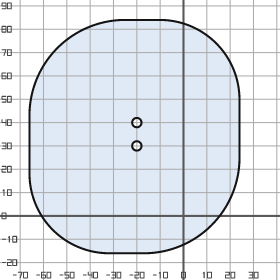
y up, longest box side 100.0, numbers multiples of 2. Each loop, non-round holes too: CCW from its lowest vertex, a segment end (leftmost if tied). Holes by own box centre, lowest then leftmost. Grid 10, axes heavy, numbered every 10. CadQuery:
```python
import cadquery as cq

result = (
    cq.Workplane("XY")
    .moveTo(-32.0, -16.0)
    .lineTo(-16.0, -16.0)
    .threePointArc((12.0, -4.0), (24.0, 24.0))
    .lineTo(24.0, 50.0)
    .threePointArc((14.0, 74.0), (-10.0, 84.0))
    .lineTo(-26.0, 84.0)
    .threePointArc((-54.0, 72.0), (-66.0, 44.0))
    .lineTo(-66.0, 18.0)
    .threePointArc((-56.0, -6.0), (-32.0, -16.0))
    .close()
    .moveTo(-20.0, 30.0)
    .circle(2.0)
    .moveTo(-20.0, 40.0)
    .circle(2.0)
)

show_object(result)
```